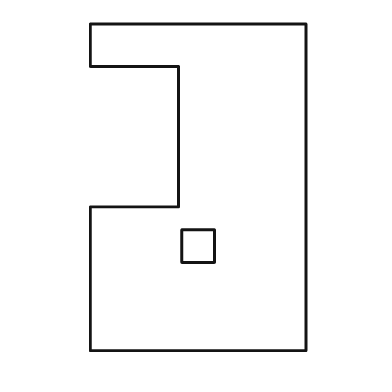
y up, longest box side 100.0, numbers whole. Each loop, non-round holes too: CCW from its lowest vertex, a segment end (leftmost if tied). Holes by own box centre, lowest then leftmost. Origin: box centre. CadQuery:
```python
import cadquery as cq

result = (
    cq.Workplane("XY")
    .moveTo(-33.0, -50.0)
    .lineTo(33.0, -50.0)
    .lineTo(33.0, 50.0)
    .lineTo(-33.0, 50.0)
    .lineTo(-33.0, 37.0)
    .lineTo(-6.0, 37.0)
    .lineTo(-6.0, -6.0)
    .lineTo(-33.0, -6.0)
    .close()
    .moveTo(-5.0, -23.0)
    .lineTo(5.0, -23.0)
    .lineTo(5.0, -13.0)
    .lineTo(-5.0, -13.0)
    .close()
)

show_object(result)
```